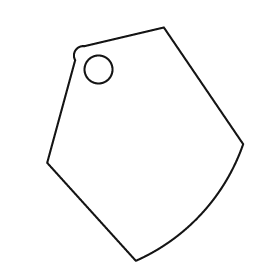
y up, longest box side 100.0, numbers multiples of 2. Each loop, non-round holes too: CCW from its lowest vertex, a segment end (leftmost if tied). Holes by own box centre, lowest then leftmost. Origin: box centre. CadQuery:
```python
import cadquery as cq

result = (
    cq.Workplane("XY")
    .moveTo(-4.0, -50.0)
    .threePointArc((24.0, -30.0), (42.0, 0.0))
    .lineTo(8.0, 50.0)
    .lineTo(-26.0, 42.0)
    .threePointArc((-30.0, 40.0), (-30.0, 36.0))
    .lineTo(-42.0, -8.0)
    .close()
    .moveTo(-20.0, 32.0)
    .circle(6.0)
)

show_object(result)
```